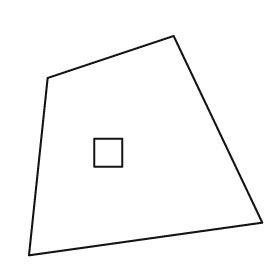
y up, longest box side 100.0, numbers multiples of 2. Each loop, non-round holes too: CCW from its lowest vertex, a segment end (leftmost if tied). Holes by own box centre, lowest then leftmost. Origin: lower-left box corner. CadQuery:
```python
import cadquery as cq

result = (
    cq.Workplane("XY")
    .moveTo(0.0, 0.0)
    .lineTo(100.0, 14.0)
    .lineTo(62.0, 94.0)
    .lineTo(8.0, 76.0)
    .close()
    .moveTo(28.0, 38.0)
    .lineTo(40.0, 38.0)
    .lineTo(40.0, 50.0)
    .lineTo(28.0, 50.0)
    .close()
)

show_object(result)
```